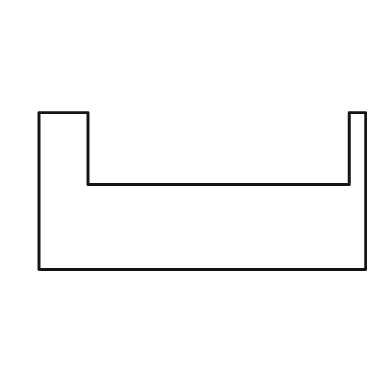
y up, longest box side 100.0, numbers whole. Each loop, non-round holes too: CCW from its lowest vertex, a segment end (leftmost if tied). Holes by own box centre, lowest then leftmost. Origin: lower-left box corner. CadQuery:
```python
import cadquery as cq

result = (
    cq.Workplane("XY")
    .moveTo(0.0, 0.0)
    .lineTo(100.0, 0.0)
    .lineTo(100.0, 48.0)
    .lineTo(95.0, 48.0)
    .lineTo(95.0, 26.0)
    .lineTo(15.0, 26.0)
    .lineTo(15.0, 48.0)
    .lineTo(0.0, 48.0)
    .close()
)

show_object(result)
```